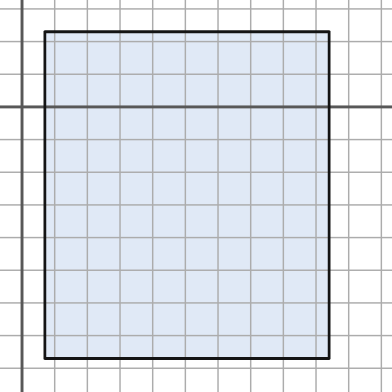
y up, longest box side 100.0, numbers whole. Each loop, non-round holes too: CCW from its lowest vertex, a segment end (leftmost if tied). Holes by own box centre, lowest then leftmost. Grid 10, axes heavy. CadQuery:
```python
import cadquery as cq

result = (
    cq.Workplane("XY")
    .moveTo(7.0, -77.0)
    .lineTo(94.0, -77.0)
    .lineTo(94.0, 23.0)
    .lineTo(7.0, 23.0)
    .close()
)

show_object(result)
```